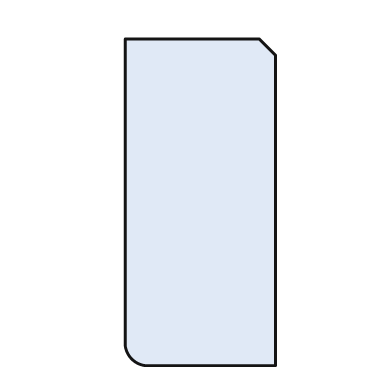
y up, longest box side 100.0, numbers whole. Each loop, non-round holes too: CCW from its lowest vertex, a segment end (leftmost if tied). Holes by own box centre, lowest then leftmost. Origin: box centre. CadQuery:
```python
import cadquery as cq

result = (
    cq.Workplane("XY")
    .moveTo(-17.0, -50.0)
    .lineTo(23.0, -50.0)
    .lineTo(23.0, 45.0)
    .lineTo(18.0, 50.0)
    .lineTo(-23.0, 50.0)
    .lineTo(-23.0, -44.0)
    .threePointArc((-21.0, -48.0), (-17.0, -50.0))
    .close()
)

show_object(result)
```